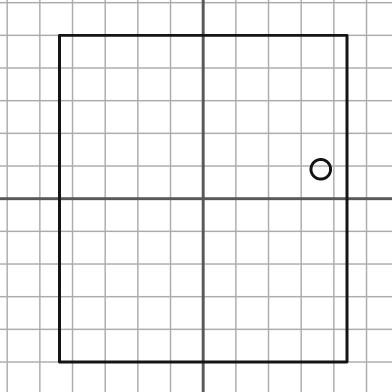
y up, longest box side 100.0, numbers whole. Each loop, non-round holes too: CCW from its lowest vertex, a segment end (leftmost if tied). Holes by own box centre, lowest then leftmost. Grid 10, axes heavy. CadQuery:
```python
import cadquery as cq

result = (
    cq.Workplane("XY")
    .moveTo(-44.0, -50.0)
    .lineTo(44.0, -50.0)
    .lineTo(44.0, 50.0)
    .lineTo(-44.0, 50.0)
    .close()
    .moveTo(36.0, 9.0)
    .circle(3.0)
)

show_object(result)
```